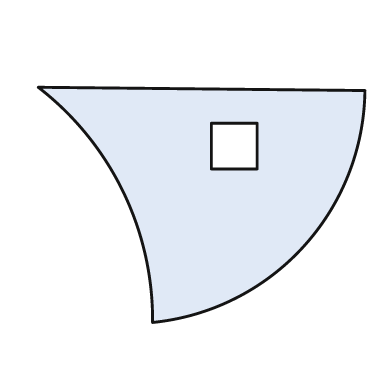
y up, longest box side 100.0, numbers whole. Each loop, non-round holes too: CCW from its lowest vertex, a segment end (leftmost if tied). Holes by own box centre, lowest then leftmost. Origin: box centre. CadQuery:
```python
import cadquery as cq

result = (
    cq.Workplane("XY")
    .moveTo(-15.0, -36.0)
    .threePointArc((31.0, -13.0), (50.0, 35.0))
    .lineTo(-50.0, 36.0)
    .threePointArc((-24.0, 4.0), (-15.0, -36.0))
    .close()
    .moveTo(3.0, 11.0)
    .lineTo(17.0, 11.0)
    .lineTo(17.0, 25.0)
    .lineTo(3.0, 25.0)
    .close()
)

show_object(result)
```